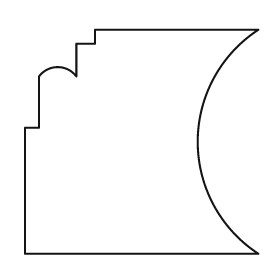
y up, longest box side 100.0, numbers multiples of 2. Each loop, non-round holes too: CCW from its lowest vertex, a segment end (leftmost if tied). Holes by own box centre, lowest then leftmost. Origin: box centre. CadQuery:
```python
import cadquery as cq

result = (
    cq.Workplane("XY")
    .moveTo(-50.0, -48.0)
    .lineTo(50.0, -48.0)
    .threePointArc((24.0, 0.0), (50.0, 48.0))
    .lineTo(-20.0, 48.0)
    .lineTo(-20.0, 42.0)
    .lineTo(-28.0, 42.0)
    .lineTo(-28.0, 28.0)
    .threePointArc((-36.0, 32.0), (-44.0, 28.0))
    .lineTo(-44.0, 6.0)
    .lineTo(-50.0, 6.0)
    .close()
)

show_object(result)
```